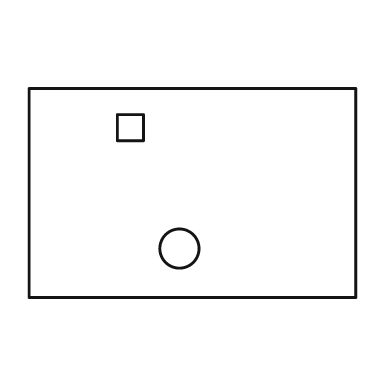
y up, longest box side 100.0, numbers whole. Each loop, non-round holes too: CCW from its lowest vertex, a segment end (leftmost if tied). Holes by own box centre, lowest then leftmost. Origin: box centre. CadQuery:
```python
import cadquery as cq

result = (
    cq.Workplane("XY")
    .moveTo(-50.0, -32.0)
    .lineTo(50.0, -32.0)
    .lineTo(50.0, 32.0)
    .lineTo(-50.0, 32.0)
    .close()
    .moveTo(-4.0, -17.0)
    .circle(6.0)
    .moveTo(-23.0, 16.0)
    .lineTo(-15.0, 16.0)
    .lineTo(-15.0, 24.0)
    .lineTo(-23.0, 24.0)
    .close()
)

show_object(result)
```